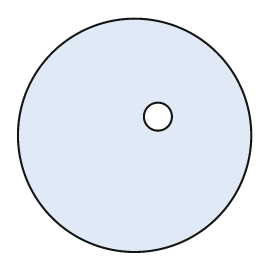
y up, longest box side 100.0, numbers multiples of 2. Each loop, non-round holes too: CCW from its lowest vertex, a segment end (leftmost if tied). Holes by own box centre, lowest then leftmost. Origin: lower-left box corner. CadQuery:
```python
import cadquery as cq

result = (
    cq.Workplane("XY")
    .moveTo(50.0, 50.0)
    .circle(50.0)
    .moveTo(60.0, 58.0)
    .circle(6.0)
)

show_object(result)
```